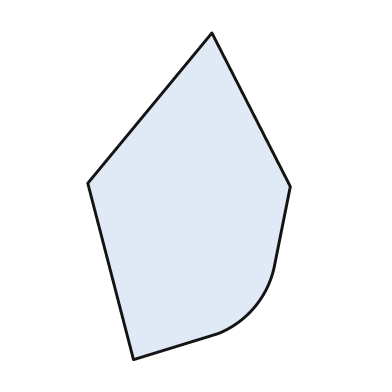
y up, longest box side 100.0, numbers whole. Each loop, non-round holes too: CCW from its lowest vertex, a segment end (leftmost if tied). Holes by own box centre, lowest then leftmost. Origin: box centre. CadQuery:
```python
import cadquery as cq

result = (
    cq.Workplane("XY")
    .moveTo(-17.0, -50.0)
    .lineTo(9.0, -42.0)
    .threePointArc((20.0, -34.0), (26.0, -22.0))
    .lineTo(31.0, 3.0)
    .lineTo(7.0, 50.0)
    .lineTo(-31.0, 4.0)
    .close()
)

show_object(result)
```